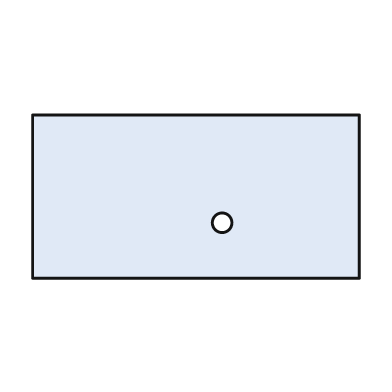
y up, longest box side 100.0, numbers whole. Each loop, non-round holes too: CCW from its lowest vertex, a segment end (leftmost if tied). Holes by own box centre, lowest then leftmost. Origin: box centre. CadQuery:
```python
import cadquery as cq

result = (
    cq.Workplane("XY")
    .moveTo(-50.0, -25.0)
    .lineTo(50.0, -25.0)
    .lineTo(50.0, 25.0)
    .lineTo(-50.0, 25.0)
    .close()
    .moveTo(8.0, -8.0)
    .circle(3.0)
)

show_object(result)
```